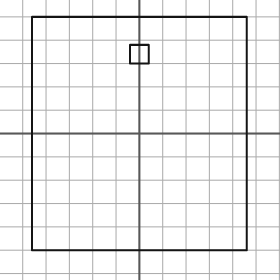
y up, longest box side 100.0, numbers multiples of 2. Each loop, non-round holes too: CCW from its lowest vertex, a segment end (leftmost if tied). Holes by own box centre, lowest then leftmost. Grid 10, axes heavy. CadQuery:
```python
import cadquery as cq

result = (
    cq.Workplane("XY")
    .moveTo(-46.0, -50.0)
    .lineTo(46.0, -50.0)
    .lineTo(46.0, 50.0)
    .lineTo(-46.0, 50.0)
    .close()
    .moveTo(-4.0, 30.0)
    .lineTo(4.0, 30.0)
    .lineTo(4.0, 38.0)
    .lineTo(-4.0, 38.0)
    .close()
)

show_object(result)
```